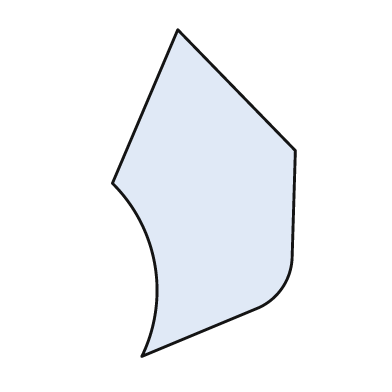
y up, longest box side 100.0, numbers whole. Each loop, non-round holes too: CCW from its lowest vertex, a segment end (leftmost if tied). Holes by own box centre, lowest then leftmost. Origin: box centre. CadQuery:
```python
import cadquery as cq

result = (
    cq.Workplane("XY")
    .moveTo(-19.0, -50.0)
    .lineTo(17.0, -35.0)
    .threePointArc((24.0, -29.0), (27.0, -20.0))
    .lineTo(28.0, 13.0)
    .lineTo(-8.0, 50.0)
    .lineTo(-28.0, 3.0)
    .threePointArc((-15.0, -22.0), (-19.0, -50.0))
    .close()
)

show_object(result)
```